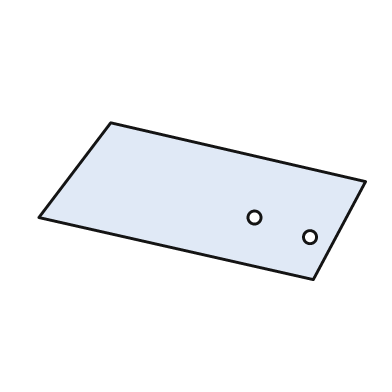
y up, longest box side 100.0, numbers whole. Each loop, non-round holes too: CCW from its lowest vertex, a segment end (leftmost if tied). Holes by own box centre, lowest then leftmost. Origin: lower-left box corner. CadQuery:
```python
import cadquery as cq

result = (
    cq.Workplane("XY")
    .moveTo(84.0, 0.0)
    .lineTo(100.0, 30.0)
    .lineTo(22.0, 48.0)
    .lineTo(0.0, 19.0)
    .close()
    .moveTo(83.0, 13.0)
    .circle(2.0)
    .moveTo(66.0, 19.0)
    .circle(2.0)
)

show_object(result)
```